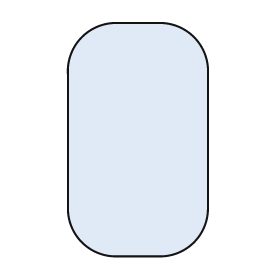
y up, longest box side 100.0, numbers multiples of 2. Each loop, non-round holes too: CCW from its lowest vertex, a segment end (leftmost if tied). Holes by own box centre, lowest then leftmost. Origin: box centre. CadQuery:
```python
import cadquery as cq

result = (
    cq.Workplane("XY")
    .moveTo(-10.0, -50.0)
    .lineTo(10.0, -50.0)
    .threePointArc((24.0, -44.0), (30.0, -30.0))
    .lineTo(30.0, 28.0)
    .threePointArc((24.0, 44.0), (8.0, 50.0))
    .lineTo(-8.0, 50.0)
    .threePointArc((-24.0, 44.0), (-30.0, 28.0))
    .lineTo(-30.0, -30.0)
    .threePointArc((-24.0, -44.0), (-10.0, -50.0))
    .close()
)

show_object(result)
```